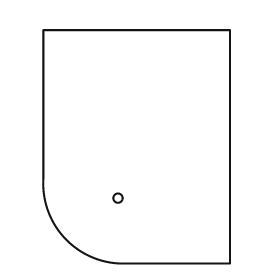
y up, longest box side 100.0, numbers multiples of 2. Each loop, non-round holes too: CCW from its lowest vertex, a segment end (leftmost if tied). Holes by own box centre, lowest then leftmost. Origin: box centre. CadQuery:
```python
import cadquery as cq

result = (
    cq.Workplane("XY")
    .moveTo(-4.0, -50.0)
    .lineTo(40.0, -50.0)
    .lineTo(40.0, 50.0)
    .lineTo(-40.0, 50.0)
    .lineTo(-40.0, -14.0)
    .threePointArc((-30.0, -40.0), (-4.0, -50.0))
    .close()
    .moveTo(-8.0, -22.0)
    .circle(2.0)
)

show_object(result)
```